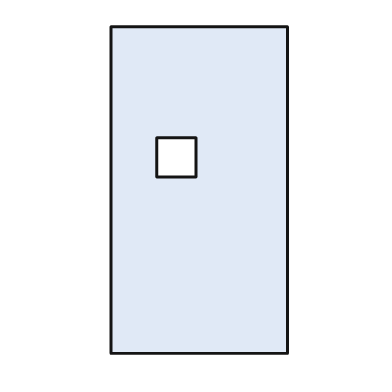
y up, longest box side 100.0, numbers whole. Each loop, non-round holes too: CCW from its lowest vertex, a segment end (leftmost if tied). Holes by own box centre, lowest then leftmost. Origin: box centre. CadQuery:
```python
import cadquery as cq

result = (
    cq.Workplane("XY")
    .moveTo(-27.0, -50.0)
    .lineTo(27.0, -50.0)
    .lineTo(27.0, 50.0)
    .lineTo(-27.0, 50.0)
    .close()
    .moveTo(-13.0, 4.0)
    .lineTo(-1.0, 4.0)
    .lineTo(-1.0, 16.0)
    .lineTo(-13.0, 16.0)
    .close()
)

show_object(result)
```